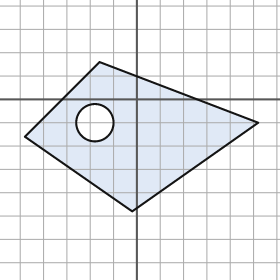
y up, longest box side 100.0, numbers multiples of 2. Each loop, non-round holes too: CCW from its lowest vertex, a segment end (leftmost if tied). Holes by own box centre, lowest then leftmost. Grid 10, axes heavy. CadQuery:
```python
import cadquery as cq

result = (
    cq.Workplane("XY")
    .moveTo(-2.0, -48.0)
    .lineTo(52.0, -10.0)
    .lineTo(-16.0, 16.0)
    .lineTo(-48.0, -16.0)
    .close()
    .moveTo(-18.0, -10.0)
    .circle(8.0)
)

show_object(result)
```